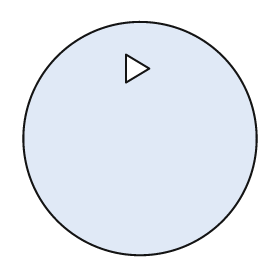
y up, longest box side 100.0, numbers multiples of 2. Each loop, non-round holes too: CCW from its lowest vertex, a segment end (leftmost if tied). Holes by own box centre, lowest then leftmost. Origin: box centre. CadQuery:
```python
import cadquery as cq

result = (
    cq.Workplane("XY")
    .moveTo(0.0, 0.0)
    .circle(50.0)
    .moveTo(-6.0, 24.0)
    .lineTo(4.0, 30.0)
    .lineTo(-6.0, 36.0)
    .close()
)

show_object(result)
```